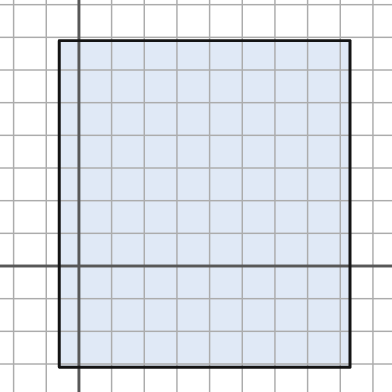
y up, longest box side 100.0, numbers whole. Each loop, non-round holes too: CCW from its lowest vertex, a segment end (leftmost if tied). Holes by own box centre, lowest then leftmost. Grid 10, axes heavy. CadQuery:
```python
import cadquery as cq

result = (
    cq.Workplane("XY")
    .moveTo(-6.0, -31.0)
    .lineTo(83.0, -31.0)
    .lineTo(83.0, 69.0)
    .lineTo(-6.0, 69.0)
    .close()
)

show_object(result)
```